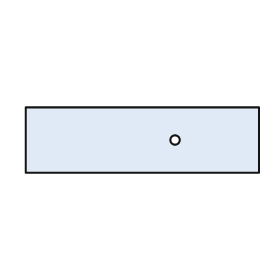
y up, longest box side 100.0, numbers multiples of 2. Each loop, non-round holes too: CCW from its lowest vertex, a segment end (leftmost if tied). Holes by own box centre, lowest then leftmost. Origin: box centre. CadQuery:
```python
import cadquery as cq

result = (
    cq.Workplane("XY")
    .moveTo(-50.0, -14.0)
    .lineTo(50.0, -14.0)
    .lineTo(50.0, 14.0)
    .lineTo(-50.0, 14.0)
    .close()
    .moveTo(14.0, 0.0)
    .circle(2.0)
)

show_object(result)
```